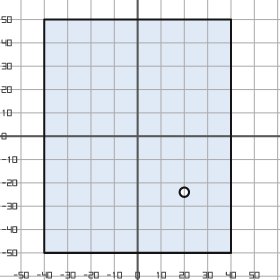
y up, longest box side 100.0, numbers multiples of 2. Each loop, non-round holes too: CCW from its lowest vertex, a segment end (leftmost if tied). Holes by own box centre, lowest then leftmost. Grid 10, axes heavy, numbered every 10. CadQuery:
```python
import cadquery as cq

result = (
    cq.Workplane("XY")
    .moveTo(-40.0, -50.0)
    .lineTo(40.0, -50.0)
    .lineTo(40.0, 50.0)
    .lineTo(-40.0, 50.0)
    .close()
    .moveTo(20.0, -24.0)
    .circle(2.0)
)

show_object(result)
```